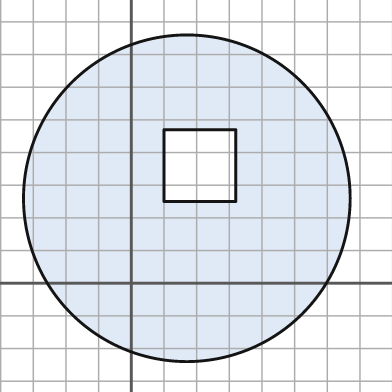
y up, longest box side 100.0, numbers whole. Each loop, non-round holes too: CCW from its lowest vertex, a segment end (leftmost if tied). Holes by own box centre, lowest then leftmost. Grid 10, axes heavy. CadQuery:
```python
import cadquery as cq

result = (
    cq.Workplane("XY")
    .moveTo(17.0, 26.0)
    .circle(50.0)
    .moveTo(10.0, 25.0)
    .lineTo(32.0, 25.0)
    .lineTo(32.0, 47.0)
    .lineTo(10.0, 47.0)
    .close()
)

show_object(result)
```